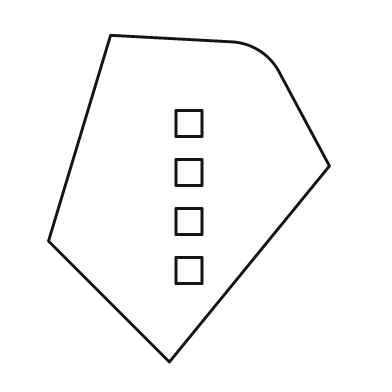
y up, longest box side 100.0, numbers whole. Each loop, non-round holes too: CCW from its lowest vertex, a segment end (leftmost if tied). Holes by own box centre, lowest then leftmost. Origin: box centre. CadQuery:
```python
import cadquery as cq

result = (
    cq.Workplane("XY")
    .moveTo(-6.0, -50.0)
    .lineTo(43.0, 10.0)
    .lineTo(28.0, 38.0)
    .threePointArc((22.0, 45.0), (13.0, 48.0))
    .lineTo(-24.0, 50.0)
    .lineTo(-43.0, -13.0)
    .close()
    .moveTo(-4.0, -26.0)
    .lineTo(4.0, -26.0)
    .lineTo(4.0, -18.0)
    .lineTo(-4.0, -18.0)
    .close()
    .moveTo(-4.0, -11.0)
    .lineTo(4.0, -11.0)
    .lineTo(4.0, -3.0)
    .lineTo(-4.0, -3.0)
    .close()
    .moveTo(-4.0, 4.0)
    .lineTo(4.0, 4.0)
    .lineTo(4.0, 12.0)
    .lineTo(-4.0, 12.0)
    .close()
    .moveTo(-4.0, 19.0)
    .lineTo(4.0, 19.0)
    .lineTo(4.0, 27.0)
    .lineTo(-4.0, 27.0)
    .close()
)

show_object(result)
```